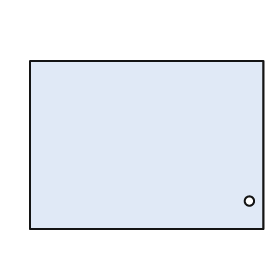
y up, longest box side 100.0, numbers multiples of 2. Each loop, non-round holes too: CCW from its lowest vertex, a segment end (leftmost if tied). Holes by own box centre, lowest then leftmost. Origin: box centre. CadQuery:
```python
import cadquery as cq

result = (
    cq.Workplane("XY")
    .moveTo(-50.0, -36.0)
    .lineTo(50.0, -36.0)
    .lineTo(50.0, 36.0)
    .lineTo(-50.0, 36.0)
    .close()
    .moveTo(44.0, -24.0)
    .circle(2.0)
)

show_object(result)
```